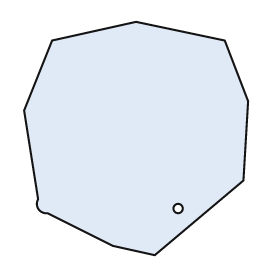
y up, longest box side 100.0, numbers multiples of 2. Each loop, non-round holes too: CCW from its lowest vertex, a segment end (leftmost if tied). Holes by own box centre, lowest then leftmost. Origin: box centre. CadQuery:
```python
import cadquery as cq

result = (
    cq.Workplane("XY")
    .moveTo(8.0, -50.0)
    .lineTo(46.0, -18.0)
    .lineTo(48.0, 16.0)
    .lineTo(38.0, 42.0)
    .lineTo(0.0, 50.0)
    .lineTo(-36.0, 42.0)
    .lineTo(-48.0, 12.0)
    .lineTo(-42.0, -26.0)
    .threePointArc((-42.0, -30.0), (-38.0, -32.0))
    .lineTo(-10.0, -46.0)
    .close()
    .moveTo(18.0, -30.0)
    .circle(2.0)
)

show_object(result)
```